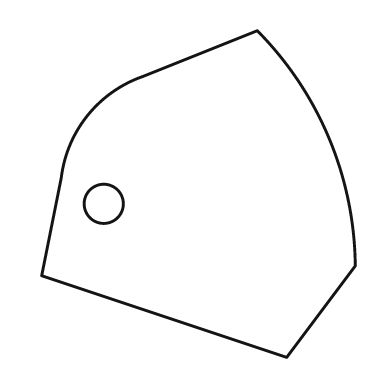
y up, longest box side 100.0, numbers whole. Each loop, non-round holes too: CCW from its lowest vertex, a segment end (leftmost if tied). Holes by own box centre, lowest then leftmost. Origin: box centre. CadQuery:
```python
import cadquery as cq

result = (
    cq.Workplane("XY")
    .moveTo(27.0, -50.0)
    .lineTo(48.0, -22.0)
    .threePointArc((40.0, 17.0), (18.0, 50.0))
    .lineTo(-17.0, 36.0)
    .threePointArc((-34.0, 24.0), (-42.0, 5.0))
    .lineTo(-48.0, -25.0)
    .close()
    .moveTo(-29.0, -3.0)
    .circle(6.0)
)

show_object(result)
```